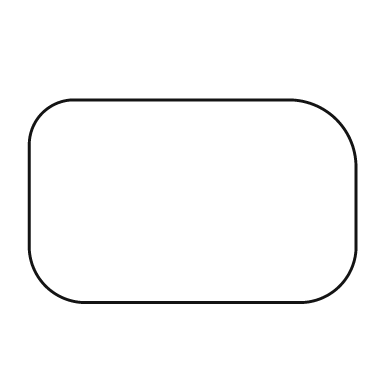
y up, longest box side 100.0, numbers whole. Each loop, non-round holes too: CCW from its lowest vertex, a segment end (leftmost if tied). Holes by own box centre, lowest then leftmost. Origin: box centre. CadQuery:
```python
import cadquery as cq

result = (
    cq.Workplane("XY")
    .moveTo(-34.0, -31.0)
    .lineTo(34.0, -31.0)
    .threePointArc((45.0, -26.0), (50.0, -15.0))
    .lineTo(50.0, 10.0)
    .threePointArc((44.0, 25.0), (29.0, 31.0))
    .lineTo(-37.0, 31.0)
    .threePointArc((-46.0, 27.0), (-50.0, 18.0))
    .lineTo(-50.0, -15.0)
    .threePointArc((-45.0, -26.0), (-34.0, -31.0))
    .close()
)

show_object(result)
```